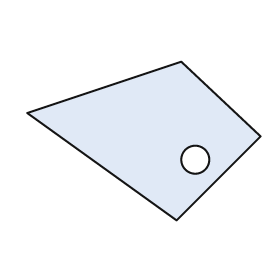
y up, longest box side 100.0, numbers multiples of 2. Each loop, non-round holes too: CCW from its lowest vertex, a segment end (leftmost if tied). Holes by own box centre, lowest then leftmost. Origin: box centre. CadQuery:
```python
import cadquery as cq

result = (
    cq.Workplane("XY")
    .moveTo(14.0, -34.0)
    .lineTo(50.0, 2.0)
    .lineTo(16.0, 34.0)
    .lineTo(-50.0, 12.0)
    .close()
    .moveTo(22.0, -8.0)
    .circle(6.0)
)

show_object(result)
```